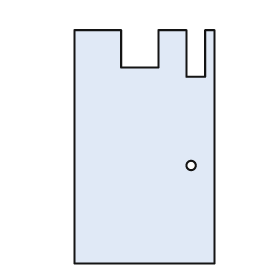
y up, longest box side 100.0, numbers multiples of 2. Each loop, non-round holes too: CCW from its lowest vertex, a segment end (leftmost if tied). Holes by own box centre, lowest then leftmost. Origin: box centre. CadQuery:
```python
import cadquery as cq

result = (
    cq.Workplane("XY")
    .moveTo(-30.0, -50.0)
    .lineTo(30.0, -50.0)
    .lineTo(30.0, 50.0)
    .lineTo(26.0, 50.0)
    .lineTo(26.0, 30.0)
    .lineTo(18.0, 30.0)
    .lineTo(18.0, 50.0)
    .lineTo(6.0, 50.0)
    .lineTo(6.0, 34.0)
    .lineTo(-10.0, 34.0)
    .lineTo(-10.0, 50.0)
    .lineTo(-30.0, 50.0)
    .close()
    .moveTo(20.0, -8.0)
    .circle(2.0)
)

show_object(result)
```